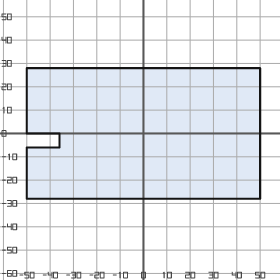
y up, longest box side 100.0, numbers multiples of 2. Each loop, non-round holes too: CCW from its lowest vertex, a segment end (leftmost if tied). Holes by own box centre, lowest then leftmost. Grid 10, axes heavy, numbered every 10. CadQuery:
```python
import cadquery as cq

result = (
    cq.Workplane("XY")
    .moveTo(-50.0, -28.0)
    .lineTo(50.0, -28.0)
    .lineTo(50.0, 28.0)
    .lineTo(-50.0, 28.0)
    .lineTo(-50.0, 0.0)
    .lineTo(-36.0, 0.0)
    .lineTo(-36.0, -6.0)
    .lineTo(-50.0, -6.0)
    .close()
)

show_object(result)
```